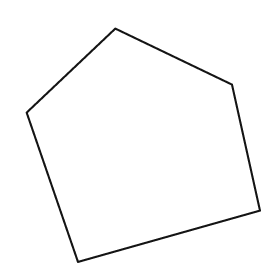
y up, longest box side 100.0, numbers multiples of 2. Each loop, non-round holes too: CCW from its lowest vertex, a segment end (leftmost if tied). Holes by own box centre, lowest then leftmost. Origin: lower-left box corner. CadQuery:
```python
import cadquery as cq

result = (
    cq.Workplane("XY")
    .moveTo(22.0, 0.0)
    .lineTo(100.0, 22.0)
    .lineTo(88.0, 76.0)
    .lineTo(38.0, 100.0)
    .lineTo(0.0, 64.0)
    .close()
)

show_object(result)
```